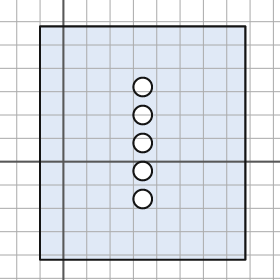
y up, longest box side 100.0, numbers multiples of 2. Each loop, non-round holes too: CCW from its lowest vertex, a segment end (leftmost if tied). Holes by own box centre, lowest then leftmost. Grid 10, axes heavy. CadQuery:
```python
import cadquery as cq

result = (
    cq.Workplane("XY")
    .moveTo(-10.0, -42.0)
    .lineTo(78.0, -42.0)
    .lineTo(78.0, 58.0)
    .lineTo(-10.0, 58.0)
    .close()
    .moveTo(34.0, -16.0)
    .circle(4.0)
    .moveTo(34.0, -4.0)
    .circle(4.0)
    .moveTo(34.0, 8.0)
    .circle(4.0)
    .moveTo(34.0, 20.0)
    .circle(4.0)
    .moveTo(34.0, 32.0)
    .circle(4.0)
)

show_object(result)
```